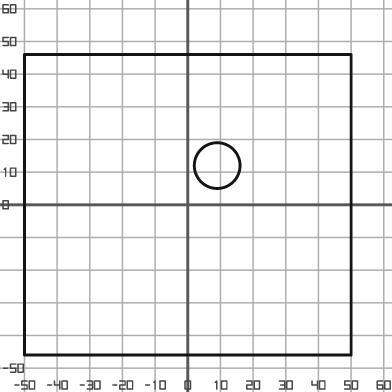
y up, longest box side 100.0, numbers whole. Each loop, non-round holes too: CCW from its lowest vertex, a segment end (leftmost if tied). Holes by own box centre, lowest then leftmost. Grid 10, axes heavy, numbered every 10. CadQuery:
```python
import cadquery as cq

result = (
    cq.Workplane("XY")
    .moveTo(-50.0, -46.0)
    .lineTo(50.0, -46.0)
    .lineTo(50.0, 46.0)
    .lineTo(-50.0, 46.0)
    .close()
    .moveTo(9.0, 12.0)
    .circle(7.0)
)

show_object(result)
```